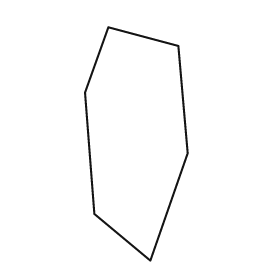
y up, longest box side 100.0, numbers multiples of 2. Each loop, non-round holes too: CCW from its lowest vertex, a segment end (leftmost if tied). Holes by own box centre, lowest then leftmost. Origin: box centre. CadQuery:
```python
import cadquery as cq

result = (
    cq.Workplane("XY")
    .moveTo(6.0, -50.0)
    .lineTo(22.0, -4.0)
    .lineTo(18.0, 42.0)
    .lineTo(-12.0, 50.0)
    .lineTo(-22.0, 22.0)
    .lineTo(-18.0, -30.0)
    .close()
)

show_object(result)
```